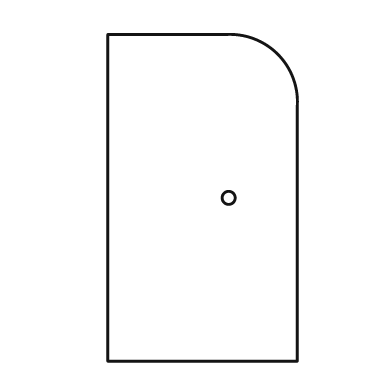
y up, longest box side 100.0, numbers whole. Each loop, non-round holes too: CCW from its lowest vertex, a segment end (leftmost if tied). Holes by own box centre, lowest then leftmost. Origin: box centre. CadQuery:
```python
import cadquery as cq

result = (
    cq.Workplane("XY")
    .moveTo(-29.0, -50.0)
    .lineTo(29.0, -50.0)
    .lineTo(29.0, 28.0)
    .threePointArc((23.0, 44.0), (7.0, 50.0))
    .lineTo(-29.0, 50.0)
    .close()
    .moveTo(8.0, 0.0)
    .circle(2.0)
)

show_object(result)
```